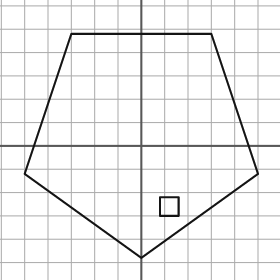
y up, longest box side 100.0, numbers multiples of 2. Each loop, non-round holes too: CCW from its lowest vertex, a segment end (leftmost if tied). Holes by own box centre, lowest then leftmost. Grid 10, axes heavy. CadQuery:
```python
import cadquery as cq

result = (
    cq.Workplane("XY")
    .moveTo(0.0, -48.0)
    .lineTo(50.0, -12.0)
    .lineTo(30.0, 48.0)
    .lineTo(-30.0, 48.0)
    .lineTo(-50.0, -12.0)
    .close()
    .moveTo(8.0, -30.0)
    .lineTo(16.0, -30.0)
    .lineTo(16.0, -22.0)
    .lineTo(8.0, -22.0)
    .close()
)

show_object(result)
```